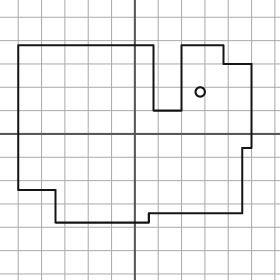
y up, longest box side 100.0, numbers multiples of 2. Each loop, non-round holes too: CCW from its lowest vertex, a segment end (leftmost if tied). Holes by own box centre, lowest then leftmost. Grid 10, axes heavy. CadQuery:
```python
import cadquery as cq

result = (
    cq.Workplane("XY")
    .moveTo(-34.0, -38.0)
    .lineTo(6.0, -38.0)
    .lineTo(6.0, -34.0)
    .lineTo(46.0, -34.0)
    .lineTo(46.0, -6.0)
    .lineTo(50.0, -6.0)
    .lineTo(50.0, 30.0)
    .lineTo(38.0, 30.0)
    .lineTo(38.0, 38.0)
    .lineTo(20.0, 38.0)
    .lineTo(20.0, 10.0)
    .lineTo(8.0, 10.0)
    .lineTo(8.0, 38.0)
    .lineTo(-50.0, 38.0)
    .lineTo(-50.0, -24.0)
    .lineTo(-34.0, -24.0)
    .close()
    .moveTo(28.0, 18.0)
    .circle(2.0)
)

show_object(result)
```